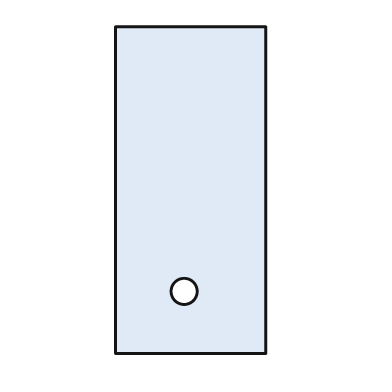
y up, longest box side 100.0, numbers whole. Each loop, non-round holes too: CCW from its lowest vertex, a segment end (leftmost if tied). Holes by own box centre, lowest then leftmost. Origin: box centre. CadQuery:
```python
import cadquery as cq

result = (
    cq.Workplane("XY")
    .moveTo(-23.0, -50.0)
    .lineTo(23.0, -50.0)
    .lineTo(23.0, 50.0)
    .lineTo(-23.0, 50.0)
    .close()
    .moveTo(-2.0, -31.0)
    .circle(4.0)
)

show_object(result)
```